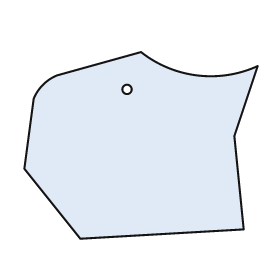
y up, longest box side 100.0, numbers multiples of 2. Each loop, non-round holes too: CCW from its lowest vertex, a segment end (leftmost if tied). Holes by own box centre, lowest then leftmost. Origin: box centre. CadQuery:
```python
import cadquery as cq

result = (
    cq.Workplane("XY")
    .moveTo(-26.0, -40.0)
    .lineTo(44.0, -36.0)
    .lineTo(40.0, 4.0)
    .lineTo(50.0, 34.0)
    .threePointArc((24.0, 30.0), (0.0, 40.0))
    .lineTo(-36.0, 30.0)
    .threePointArc((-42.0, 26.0), (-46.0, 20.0))
    .lineTo(-50.0, -10.0)
    .close()
    .moveTo(-6.0, 24.0)
    .circle(2.0)
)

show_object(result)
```